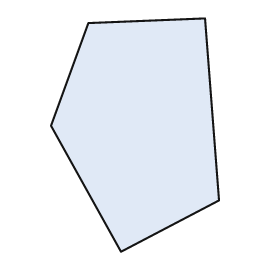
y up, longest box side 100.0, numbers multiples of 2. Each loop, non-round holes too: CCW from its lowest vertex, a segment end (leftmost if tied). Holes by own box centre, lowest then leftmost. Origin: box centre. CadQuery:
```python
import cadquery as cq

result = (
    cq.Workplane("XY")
    .moveTo(-6.0, -50.0)
    .lineTo(36.0, -28.0)
    .lineTo(30.0, 50.0)
    .lineTo(-20.0, 48.0)
    .lineTo(-36.0, 4.0)
    .close()
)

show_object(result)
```